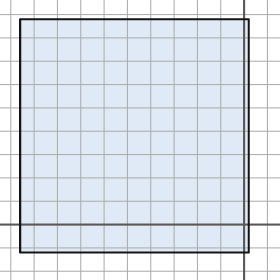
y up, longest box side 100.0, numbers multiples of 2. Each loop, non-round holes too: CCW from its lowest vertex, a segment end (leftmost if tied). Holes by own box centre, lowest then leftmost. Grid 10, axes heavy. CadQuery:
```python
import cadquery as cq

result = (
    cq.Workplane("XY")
    .moveTo(-96.0, -12.0)
    .lineTo(2.0, -12.0)
    .lineTo(2.0, 88.0)
    .lineTo(-96.0, 88.0)
    .close()
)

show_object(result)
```